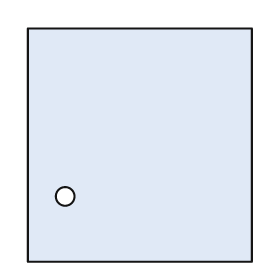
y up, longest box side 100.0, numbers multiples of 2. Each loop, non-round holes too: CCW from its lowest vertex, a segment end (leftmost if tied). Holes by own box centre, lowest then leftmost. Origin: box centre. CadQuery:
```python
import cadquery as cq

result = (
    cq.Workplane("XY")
    .moveTo(-48.0, -50.0)
    .lineTo(48.0, -50.0)
    .lineTo(48.0, 50.0)
    .lineTo(-48.0, 50.0)
    .close()
    .moveTo(-32.0, -22.0)
    .circle(4.0)
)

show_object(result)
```